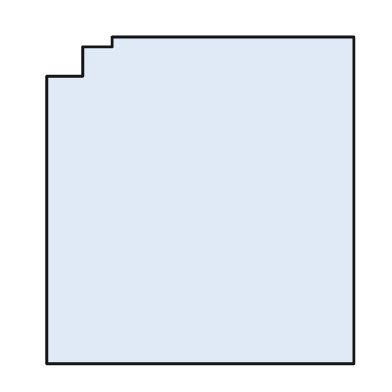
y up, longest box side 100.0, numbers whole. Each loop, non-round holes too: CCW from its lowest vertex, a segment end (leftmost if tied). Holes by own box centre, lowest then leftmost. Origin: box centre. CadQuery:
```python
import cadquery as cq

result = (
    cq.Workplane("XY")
    .moveTo(-47.0, -50.0)
    .lineTo(47.0, -50.0)
    .lineTo(47.0, 50.0)
    .lineTo(-27.0, 50.0)
    .lineTo(-27.0, 47.0)
    .lineTo(-36.0, 47.0)
    .lineTo(-36.0, 38.0)
    .lineTo(-47.0, 38.0)
    .close()
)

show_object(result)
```